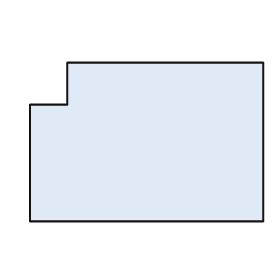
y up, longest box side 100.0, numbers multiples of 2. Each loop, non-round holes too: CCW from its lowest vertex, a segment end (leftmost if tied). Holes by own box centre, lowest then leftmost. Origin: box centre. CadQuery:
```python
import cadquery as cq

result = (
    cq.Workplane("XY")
    .moveTo(-50.0, -34.0)
    .lineTo(50.0, -34.0)
    .lineTo(50.0, 34.0)
    .lineTo(-34.0, 34.0)
    .lineTo(-34.0, 16.0)
    .lineTo(-50.0, 16.0)
    .close()
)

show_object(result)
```